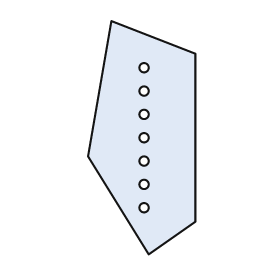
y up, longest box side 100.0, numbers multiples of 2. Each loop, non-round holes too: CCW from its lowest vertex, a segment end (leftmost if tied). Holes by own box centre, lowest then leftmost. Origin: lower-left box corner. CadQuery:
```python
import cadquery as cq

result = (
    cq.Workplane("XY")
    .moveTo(26.0, 0.0)
    .lineTo(46.0, 14.0)
    .lineTo(46.0, 86.0)
    .lineTo(10.0, 100.0)
    .lineTo(0.0, 42.0)
    .close()
    .moveTo(24.0, 20.0)
    .circle(2.0)
    .moveTo(24.0, 30.0)
    .circle(2.0)
    .moveTo(24.0, 40.0)
    .circle(2.0)
    .moveTo(24.0, 50.0)
    .circle(2.0)
    .moveTo(24.0, 60.0)
    .circle(2.0)
    .moveTo(24.0, 70.0)
    .circle(2.0)
    .moveTo(24.0, 80.0)
    .circle(2.0)
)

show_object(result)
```